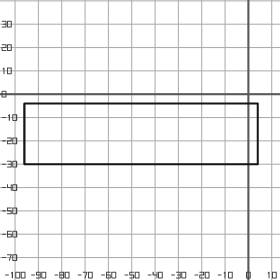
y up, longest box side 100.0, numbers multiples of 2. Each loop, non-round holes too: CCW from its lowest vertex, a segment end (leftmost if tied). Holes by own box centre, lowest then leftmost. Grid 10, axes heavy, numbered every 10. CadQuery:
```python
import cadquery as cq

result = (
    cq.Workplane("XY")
    .moveTo(-96.0, -30.0)
    .lineTo(4.0, -30.0)
    .lineTo(4.0, -4.0)
    .lineTo(-96.0, -4.0)
    .close()
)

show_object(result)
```